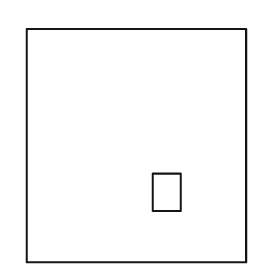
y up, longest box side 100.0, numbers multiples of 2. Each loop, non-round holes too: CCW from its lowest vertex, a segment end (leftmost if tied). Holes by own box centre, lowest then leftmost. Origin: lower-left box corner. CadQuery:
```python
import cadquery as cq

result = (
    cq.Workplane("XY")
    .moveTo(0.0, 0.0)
    .lineTo(94.0, 0.0)
    .lineTo(94.0, 100.0)
    .lineTo(0.0, 100.0)
    .close()
    .moveTo(54.0, 22.0)
    .lineTo(66.0, 22.0)
    .lineTo(66.0, 38.0)
    .lineTo(54.0, 38.0)
    .close()
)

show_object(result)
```